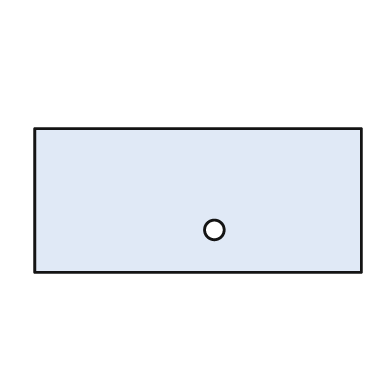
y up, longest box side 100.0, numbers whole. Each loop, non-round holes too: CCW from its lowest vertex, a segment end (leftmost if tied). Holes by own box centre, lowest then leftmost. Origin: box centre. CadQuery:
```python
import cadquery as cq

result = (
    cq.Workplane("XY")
    .moveTo(-50.0, -22.0)
    .lineTo(50.0, -22.0)
    .lineTo(50.0, 22.0)
    .lineTo(-50.0, 22.0)
    .close()
    .moveTo(5.0, -9.0)
    .circle(3.0)
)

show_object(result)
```